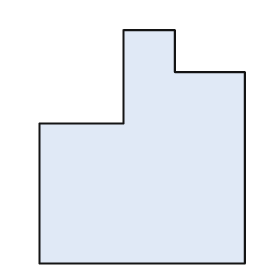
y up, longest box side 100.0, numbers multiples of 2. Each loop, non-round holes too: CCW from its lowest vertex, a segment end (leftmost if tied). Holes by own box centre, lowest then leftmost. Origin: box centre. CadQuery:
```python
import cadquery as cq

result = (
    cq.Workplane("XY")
    .moveTo(-44.0, -50.0)
    .lineTo(44.0, -50.0)
    .lineTo(44.0, 32.0)
    .lineTo(14.0, 32.0)
    .lineTo(14.0, 50.0)
    .lineTo(-8.0, 50.0)
    .lineTo(-8.0, 10.0)
    .lineTo(-44.0, 10.0)
    .close()
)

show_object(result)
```